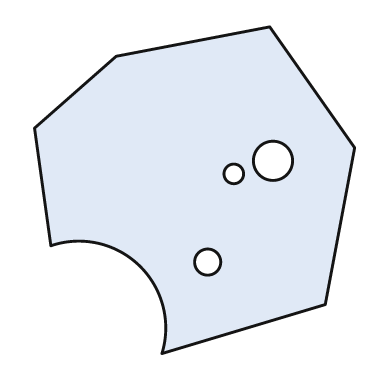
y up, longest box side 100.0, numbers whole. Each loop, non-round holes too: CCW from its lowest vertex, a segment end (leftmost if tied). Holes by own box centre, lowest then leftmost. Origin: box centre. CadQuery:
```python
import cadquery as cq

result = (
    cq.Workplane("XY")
    .moveTo(-10.0, -50.0)
    .lineTo(40.0, -35.0)
    .lineTo(49.0, 13.0)
    .lineTo(23.0, 50.0)
    .lineTo(-24.0, 41.0)
    .lineTo(-49.0, 19.0)
    .lineTo(-44.0, -17.0)
    .threePointArc((-17.0, -23.0), (-10.0, -50.0))
    .close()
    .moveTo(4.0, -22.0)
    .circle(4.0)
    .moveTo(12.0, 5.0)
    .circle(3.0)
    .moveTo(24.0, 9.0)
    .circle(6.0)
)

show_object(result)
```